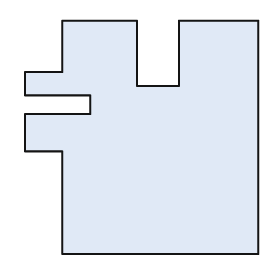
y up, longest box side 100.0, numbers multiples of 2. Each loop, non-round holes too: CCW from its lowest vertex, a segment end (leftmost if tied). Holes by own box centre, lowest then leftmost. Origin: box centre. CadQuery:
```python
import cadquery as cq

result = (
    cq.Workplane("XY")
    .moveTo(-34.0, -50.0)
    .lineTo(50.0, -50.0)
    .lineTo(50.0, 50.0)
    .lineTo(16.0, 50.0)
    .lineTo(16.0, 22.0)
    .lineTo(-2.0, 22.0)
    .lineTo(-2.0, 50.0)
    .lineTo(-34.0, 50.0)
    .lineTo(-34.0, 28.0)
    .lineTo(-50.0, 28.0)
    .lineTo(-50.0, 18.0)
    .lineTo(-22.0, 18.0)
    .lineTo(-22.0, 10.0)
    .lineTo(-50.0, 10.0)
    .lineTo(-50.0, -6.0)
    .lineTo(-34.0, -6.0)
    .close()
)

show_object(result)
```